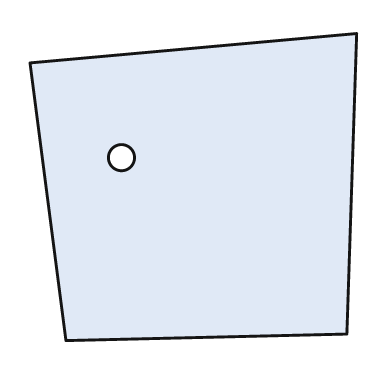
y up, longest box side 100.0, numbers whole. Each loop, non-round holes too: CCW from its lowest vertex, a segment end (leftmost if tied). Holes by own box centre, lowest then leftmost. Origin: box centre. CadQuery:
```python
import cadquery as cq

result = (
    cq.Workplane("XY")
    .moveTo(-39.0, -47.0)
    .lineTo(47.0, -45.0)
    .lineTo(50.0, 47.0)
    .lineTo(-50.0, 38.0)
    .close()
    .moveTo(-22.0, 9.0)
    .circle(4.0)
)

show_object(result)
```